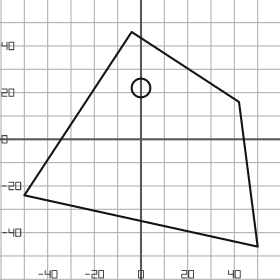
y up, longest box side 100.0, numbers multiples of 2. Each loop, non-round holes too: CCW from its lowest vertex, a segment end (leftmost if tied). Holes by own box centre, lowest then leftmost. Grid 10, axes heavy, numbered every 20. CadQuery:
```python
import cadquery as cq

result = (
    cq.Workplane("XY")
    .moveTo(50.0, -46.0)
    .lineTo(42.0, 16.0)
    .lineTo(-4.0, 46.0)
    .lineTo(-50.0, -24.0)
    .close()
    .moveTo(0.0, 22.0)
    .circle(4.0)
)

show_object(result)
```